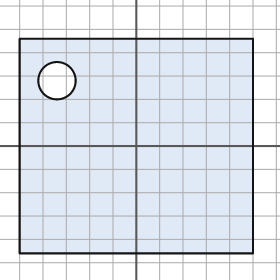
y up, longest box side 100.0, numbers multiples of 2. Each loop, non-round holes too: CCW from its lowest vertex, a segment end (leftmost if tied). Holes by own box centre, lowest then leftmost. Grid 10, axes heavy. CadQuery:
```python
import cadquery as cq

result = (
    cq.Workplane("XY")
    .moveTo(-50.0, -46.0)
    .lineTo(50.0, -46.0)
    .lineTo(50.0, 46.0)
    .lineTo(-50.0, 46.0)
    .close()
    .moveTo(-34.0, 28.0)
    .circle(8.0)
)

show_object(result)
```